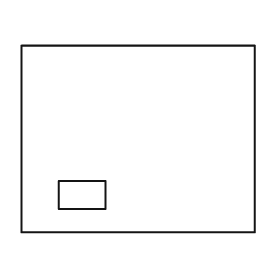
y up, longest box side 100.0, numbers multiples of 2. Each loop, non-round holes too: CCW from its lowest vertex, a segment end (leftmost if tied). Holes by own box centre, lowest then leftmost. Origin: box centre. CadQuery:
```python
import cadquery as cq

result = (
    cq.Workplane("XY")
    .moveTo(-50.0, -40.0)
    .lineTo(50.0, -40.0)
    .lineTo(50.0, 40.0)
    .lineTo(-50.0, 40.0)
    .close()
    .moveTo(-34.0, -30.0)
    .lineTo(-14.0, -30.0)
    .lineTo(-14.0, -18.0)
    .lineTo(-34.0, -18.0)
    .close()
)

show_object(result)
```